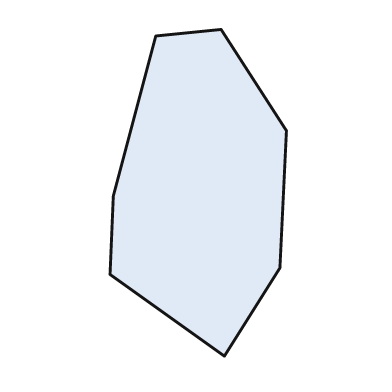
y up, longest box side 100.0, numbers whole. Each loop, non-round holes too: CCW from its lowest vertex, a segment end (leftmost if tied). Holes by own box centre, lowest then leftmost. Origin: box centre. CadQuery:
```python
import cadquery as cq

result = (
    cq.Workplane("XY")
    .moveTo(8.0, -50.0)
    .lineTo(25.0, -23.0)
    .lineTo(27.0, 19.0)
    .lineTo(7.0, 50.0)
    .lineTo(-13.0, 48.0)
    .lineTo(-26.0, -1.0)
    .lineTo(-27.0, -25.0)
    .close()
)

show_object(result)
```